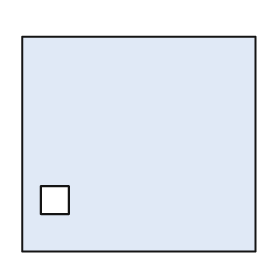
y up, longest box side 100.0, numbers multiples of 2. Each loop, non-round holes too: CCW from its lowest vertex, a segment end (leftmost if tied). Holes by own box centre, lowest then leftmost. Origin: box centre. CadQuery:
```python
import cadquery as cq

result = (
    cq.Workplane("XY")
    .moveTo(-50.0, -46.0)
    .lineTo(50.0, -46.0)
    .lineTo(50.0, 46.0)
    .lineTo(-50.0, 46.0)
    .close()
    .moveTo(-42.0, -30.0)
    .lineTo(-30.0, -30.0)
    .lineTo(-30.0, -18.0)
    .lineTo(-42.0, -18.0)
    .close()
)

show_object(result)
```